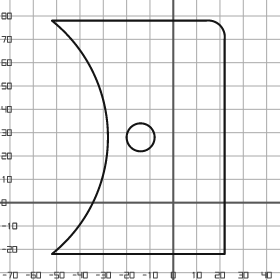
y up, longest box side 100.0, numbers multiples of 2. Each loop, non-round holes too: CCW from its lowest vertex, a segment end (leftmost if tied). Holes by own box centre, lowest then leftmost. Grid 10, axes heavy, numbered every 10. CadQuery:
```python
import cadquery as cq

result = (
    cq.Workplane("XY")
    .moveTo(-52.0, -22.0)
    .lineTo(22.0, -22.0)
    .lineTo(22.0, 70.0)
    .threePointArc((20.0, 76.0), (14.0, 78.0))
    .lineTo(-52.0, 78.0)
    .threePointArc((-28.0, 28.0), (-52.0, -22.0))
    .close()
    .moveTo(-14.0, 28.0)
    .circle(6.0)
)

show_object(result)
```